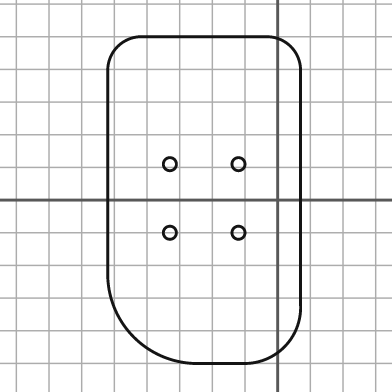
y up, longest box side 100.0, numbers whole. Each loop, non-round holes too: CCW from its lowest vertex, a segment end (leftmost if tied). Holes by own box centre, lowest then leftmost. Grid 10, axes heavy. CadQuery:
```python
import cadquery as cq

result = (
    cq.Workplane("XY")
    .moveTo(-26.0, -50.0)
    .lineTo(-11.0, -50.0)
    .threePointArc((2.0, -45.0), (7.0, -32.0))
    .lineTo(7.0, 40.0)
    .threePointArc((4.0, 47.0), (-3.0, 50.0))
    .lineTo(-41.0, 50.0)
    .threePointArc((-49.0, 47.0), (-52.0, 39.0))
    .lineTo(-52.0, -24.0)
    .threePointArc((-44.0, -42.0), (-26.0, -50.0))
    .close()
    .moveTo(-33.0, -10.0)
    .circle(2.0)
    .moveTo(-12.0, -10.0)
    .circle(2.0)
    .moveTo(-33.0, 11.0)
    .circle(2.0)
    .moveTo(-12.0, 11.0)
    .circle(2.0)
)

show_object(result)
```